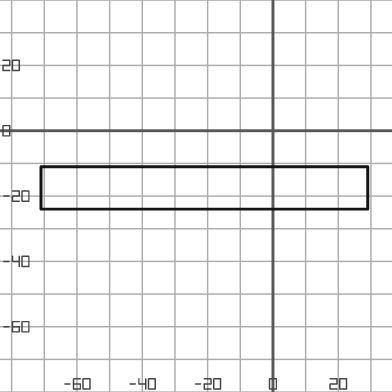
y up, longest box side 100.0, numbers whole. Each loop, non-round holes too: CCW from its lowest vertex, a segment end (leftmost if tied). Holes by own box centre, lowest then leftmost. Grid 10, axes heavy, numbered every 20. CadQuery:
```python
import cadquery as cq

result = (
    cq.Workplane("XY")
    .moveTo(-71.0, -24.0)
    .lineTo(29.0, -24.0)
    .lineTo(29.0, -11.0)
    .lineTo(-71.0, -11.0)
    .close()
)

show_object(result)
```